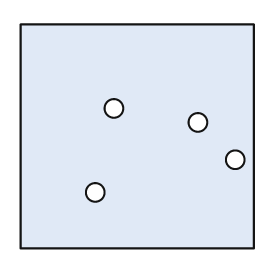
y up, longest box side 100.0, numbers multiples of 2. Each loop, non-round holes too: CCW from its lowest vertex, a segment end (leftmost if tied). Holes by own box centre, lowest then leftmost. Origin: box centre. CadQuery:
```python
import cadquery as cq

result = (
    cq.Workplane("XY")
    .moveTo(-50.0, -48.0)
    .lineTo(50.0, -48.0)
    .lineTo(50.0, 48.0)
    .lineTo(-50.0, 48.0)
    .close()
    .moveTo(-18.0, -24.0)
    .circle(4.0)
    .moveTo(42.0, -10.0)
    .circle(4.0)
    .moveTo(26.0, 6.0)
    .circle(4.0)
    .moveTo(-10.0, 12.0)
    .circle(4.0)
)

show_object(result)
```